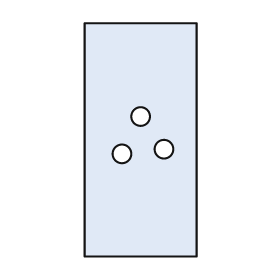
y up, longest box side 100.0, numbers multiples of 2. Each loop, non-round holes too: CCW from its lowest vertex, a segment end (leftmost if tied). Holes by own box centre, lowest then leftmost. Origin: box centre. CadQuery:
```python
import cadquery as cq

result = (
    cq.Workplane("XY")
    .moveTo(-24.0, -50.0)
    .lineTo(24.0, -50.0)
    .lineTo(24.0, 50.0)
    .lineTo(-24.0, 50.0)
    .close()
    .moveTo(-8.0, -6.0)
    .circle(4.0)
    .moveTo(10.0, -4.0)
    .circle(4.0)
    .moveTo(0.0, 10.0)
    .circle(4.0)
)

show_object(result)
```